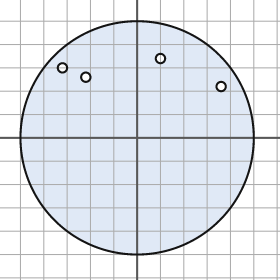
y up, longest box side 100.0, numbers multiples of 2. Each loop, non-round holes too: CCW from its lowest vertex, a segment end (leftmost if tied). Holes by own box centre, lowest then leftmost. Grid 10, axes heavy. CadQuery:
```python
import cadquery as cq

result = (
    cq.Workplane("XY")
    .moveTo(0.0, 0.0)
    .circle(50.0)
    .moveTo(36.0, 22.0)
    .circle(2.0)
    .moveTo(-22.0, 26.0)
    .circle(2.0)
    .moveTo(-32.0, 30.0)
    .circle(2.0)
    .moveTo(10.0, 34.0)
    .circle(2.0)
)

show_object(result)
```